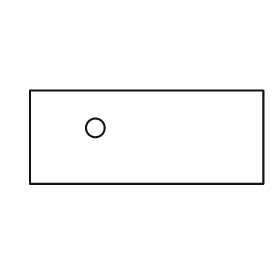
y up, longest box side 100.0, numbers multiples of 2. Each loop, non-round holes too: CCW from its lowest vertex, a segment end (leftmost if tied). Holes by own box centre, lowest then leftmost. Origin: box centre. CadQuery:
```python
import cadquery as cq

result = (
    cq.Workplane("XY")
    .moveTo(-50.0, -20.0)
    .lineTo(50.0, -20.0)
    .lineTo(50.0, 20.0)
    .lineTo(-50.0, 20.0)
    .close()
    .moveTo(-22.0, 4.0)
    .circle(4.0)
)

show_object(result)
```